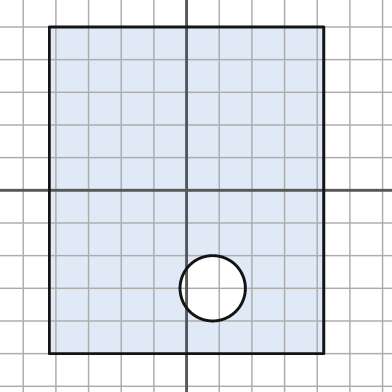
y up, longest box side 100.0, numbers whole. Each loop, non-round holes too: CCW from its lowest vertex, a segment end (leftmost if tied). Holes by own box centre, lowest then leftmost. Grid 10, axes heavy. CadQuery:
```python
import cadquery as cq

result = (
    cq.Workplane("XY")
    .moveTo(-42.0, -50.0)
    .lineTo(42.0, -50.0)
    .lineTo(42.0, 50.0)
    .lineTo(-42.0, 50.0)
    .close()
    .moveTo(8.0, -30.0)
    .circle(10.0)
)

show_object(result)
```